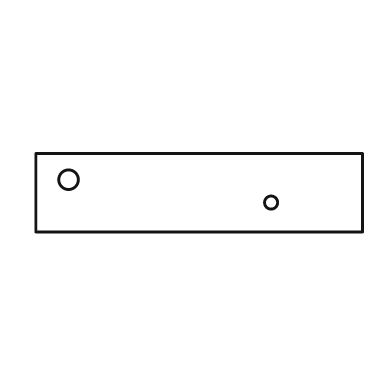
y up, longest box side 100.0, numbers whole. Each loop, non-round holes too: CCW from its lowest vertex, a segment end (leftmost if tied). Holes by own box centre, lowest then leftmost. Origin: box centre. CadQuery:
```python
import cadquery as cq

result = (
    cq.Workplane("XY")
    .moveTo(-50.0, -12.0)
    .lineTo(50.0, -12.0)
    .lineTo(50.0, 12.0)
    .lineTo(-50.0, 12.0)
    .close()
    .moveTo(22.0, -3.0)
    .circle(2.0)
    .moveTo(-40.0, 4.0)
    .circle(3.0)
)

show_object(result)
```